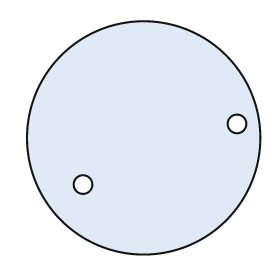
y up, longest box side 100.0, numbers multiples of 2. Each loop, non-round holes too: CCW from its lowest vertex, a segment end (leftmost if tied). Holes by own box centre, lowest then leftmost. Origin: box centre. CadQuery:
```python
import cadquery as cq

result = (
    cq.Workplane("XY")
    .moveTo(0.0, 0.0)
    .circle(50.0)
    .moveTo(-26.0, -20.0)
    .circle(4.0)
    .moveTo(40.0, 6.0)
    .circle(4.0)
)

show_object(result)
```